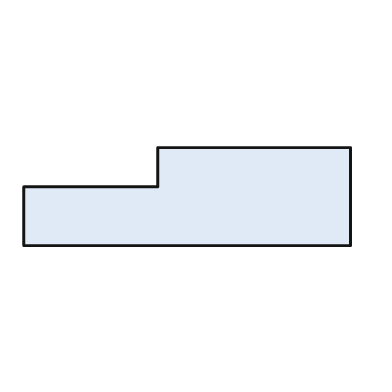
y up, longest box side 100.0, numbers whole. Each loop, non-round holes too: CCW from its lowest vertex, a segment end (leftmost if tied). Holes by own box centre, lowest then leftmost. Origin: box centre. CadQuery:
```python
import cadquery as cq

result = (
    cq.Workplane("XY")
    .moveTo(-50.0, -15.0)
    .lineTo(50.0, -15.0)
    .lineTo(50.0, 15.0)
    .lineTo(-9.0, 15.0)
    .lineTo(-9.0, 3.0)
    .lineTo(-50.0, 3.0)
    .close()
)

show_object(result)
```